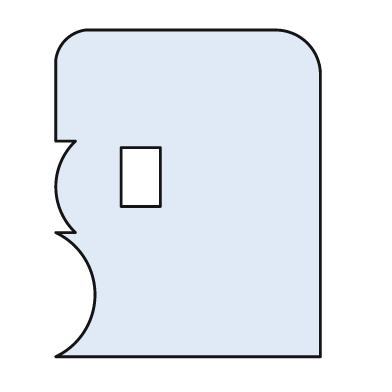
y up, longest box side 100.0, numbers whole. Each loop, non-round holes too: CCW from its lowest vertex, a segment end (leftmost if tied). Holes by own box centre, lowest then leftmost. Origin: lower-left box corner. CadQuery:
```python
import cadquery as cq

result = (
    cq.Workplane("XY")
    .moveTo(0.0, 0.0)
    .lineTo(81.0, 0.0)
    .lineTo(81.0, 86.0)
    .threePointArc((77.0, 96.0), (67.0, 100.0))
    .lineTo(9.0, 100.0)
    .threePointArc((3.0, 97.0), (0.0, 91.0))
    .lineTo(0.0, 66.0)
    .lineTo(6.0, 66.0)
    .threePointArc((0.0, 52.0), (6.0, 38.0))
    .lineTo(0.0, 38.0)
    .threePointArc((12.0, 19.0), (0.0, 0.0))
    .close()
    .moveTo(20.0, 46.0)
    .lineTo(32.0, 46.0)
    .lineTo(32.0, 64.0)
    .lineTo(20.0, 64.0)
    .close()
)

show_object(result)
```